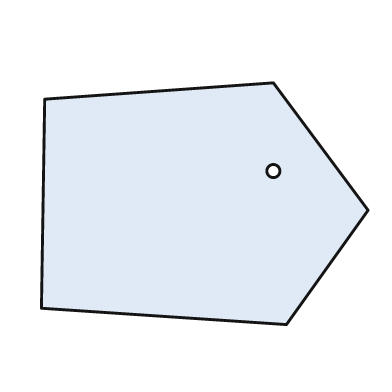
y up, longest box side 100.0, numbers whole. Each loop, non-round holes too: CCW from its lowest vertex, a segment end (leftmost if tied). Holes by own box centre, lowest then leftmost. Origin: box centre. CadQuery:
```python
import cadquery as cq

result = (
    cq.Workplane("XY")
    .moveTo(25.0, -37.0)
    .lineTo(50.0, -2.0)
    .lineTo(21.0, 37.0)
    .lineTo(-49.0, 32.0)
    .lineTo(-50.0, -32.0)
    .close()
    .moveTo(21.0, 10.0)
    .circle(2.0)
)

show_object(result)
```